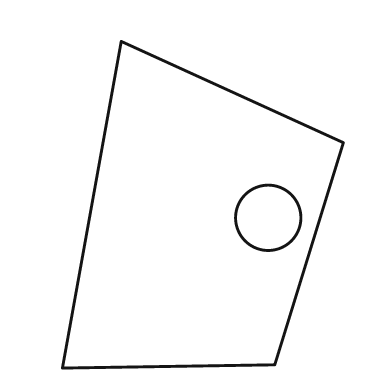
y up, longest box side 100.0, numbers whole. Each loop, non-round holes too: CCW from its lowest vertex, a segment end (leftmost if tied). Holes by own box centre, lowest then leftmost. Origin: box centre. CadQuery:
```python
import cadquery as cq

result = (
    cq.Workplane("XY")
    .moveTo(-43.0, -50.0)
    .lineTo(22.0, -49.0)
    .lineTo(43.0, 19.0)
    .lineTo(-25.0, 50.0)
    .close()
    .moveTo(20.0, -4.0)
    .circle(10.0)
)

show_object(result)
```